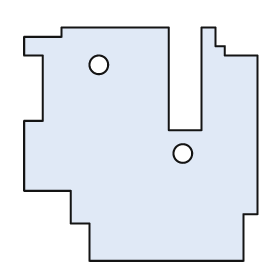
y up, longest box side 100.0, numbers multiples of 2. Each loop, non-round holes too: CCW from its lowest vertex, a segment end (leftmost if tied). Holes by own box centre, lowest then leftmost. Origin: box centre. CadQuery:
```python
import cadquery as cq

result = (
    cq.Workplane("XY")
    .moveTo(-22.0, -50.0)
    .lineTo(44.0, -50.0)
    .lineTo(44.0, -30.0)
    .lineTo(50.0, -30.0)
    .lineTo(50.0, 38.0)
    .lineTo(36.0, 38.0)
    .lineTo(36.0, 42.0)
    .lineTo(32.0, 42.0)
    .lineTo(32.0, 50.0)
    .lineTo(26.0, 50.0)
    .lineTo(26.0, 6.0)
    .lineTo(12.0, 6.0)
    .lineTo(12.0, 50.0)
    .lineTo(-34.0, 50.0)
    .lineTo(-34.0, 46.0)
    .lineTo(-50.0, 46.0)
    .lineTo(-50.0, 38.0)
    .lineTo(-42.0, 38.0)
    .lineTo(-42.0, 10.0)
    .lineTo(-50.0, 10.0)
    .lineTo(-50.0, -20.0)
    .lineTo(-30.0, -20.0)
    .lineTo(-30.0, -34.0)
    .lineTo(-22.0, -34.0)
    .close()
    .moveTo(18.0, -4.0)
    .circle(4.0)
    .moveTo(-18.0, 34.0)
    .circle(4.0)
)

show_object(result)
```